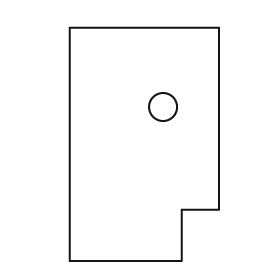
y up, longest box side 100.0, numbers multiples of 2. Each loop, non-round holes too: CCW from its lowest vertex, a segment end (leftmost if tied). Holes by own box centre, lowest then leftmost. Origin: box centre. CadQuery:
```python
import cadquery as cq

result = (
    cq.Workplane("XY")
    .moveTo(-32.0, -50.0)
    .lineTo(16.0, -50.0)
    .lineTo(16.0, -28.0)
    .lineTo(32.0, -28.0)
    .lineTo(32.0, 50.0)
    .lineTo(-32.0, 50.0)
    .close()
    .moveTo(8.0, 16.0)
    .circle(6.0)
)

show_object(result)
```